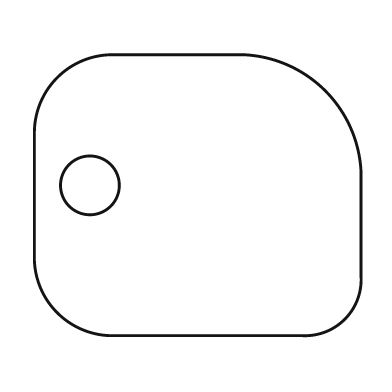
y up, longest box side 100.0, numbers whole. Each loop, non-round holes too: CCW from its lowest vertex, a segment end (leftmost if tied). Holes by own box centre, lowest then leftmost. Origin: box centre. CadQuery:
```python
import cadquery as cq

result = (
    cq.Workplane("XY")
    .moveTo(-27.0, -43.0)
    .lineTo(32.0, -43.0)
    .threePointArc((45.0, -38.0), (50.0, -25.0))
    .lineTo(50.0, 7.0)
    .threePointArc((39.0, 32.0), (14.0, 43.0))
    .lineTo(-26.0, 43.0)
    .threePointArc((-43.0, 36.0), (-50.0, 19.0))
    .lineTo(-50.0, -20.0)
    .threePointArc((-43.0, -36.0), (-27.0, -43.0))
    .close()
    .moveTo(-33.0, 3.0)
    .circle(9.0)
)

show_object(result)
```